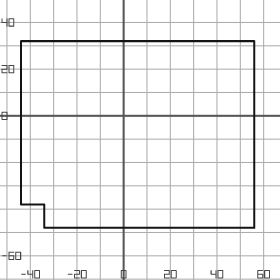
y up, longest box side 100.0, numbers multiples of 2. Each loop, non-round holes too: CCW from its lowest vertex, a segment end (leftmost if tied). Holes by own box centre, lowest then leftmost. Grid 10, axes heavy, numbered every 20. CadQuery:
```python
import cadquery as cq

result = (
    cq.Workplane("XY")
    .moveTo(-34.0, -48.0)
    .lineTo(56.0, -48.0)
    .lineTo(56.0, 32.0)
    .lineTo(-44.0, 32.0)
    .lineTo(-44.0, -38.0)
    .lineTo(-34.0, -38.0)
    .close()
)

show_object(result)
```